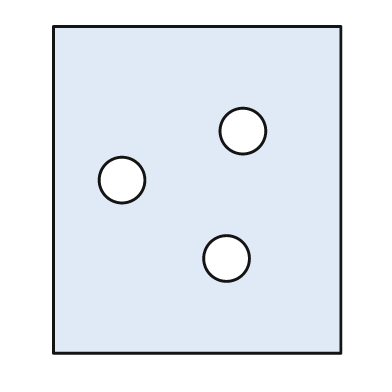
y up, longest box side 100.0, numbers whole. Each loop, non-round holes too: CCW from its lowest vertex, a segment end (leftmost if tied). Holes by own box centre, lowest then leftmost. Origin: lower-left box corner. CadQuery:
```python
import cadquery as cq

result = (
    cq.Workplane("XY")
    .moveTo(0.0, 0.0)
    .lineTo(88.0, 0.0)
    .lineTo(88.0, 100.0)
    .lineTo(0.0, 100.0)
    .close()
    .moveTo(53.0, 29.0)
    .circle(7.0)
    .moveTo(21.0, 53.0)
    .circle(7.0)
    .moveTo(58.0, 68.0)
    .circle(7.0)
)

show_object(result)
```